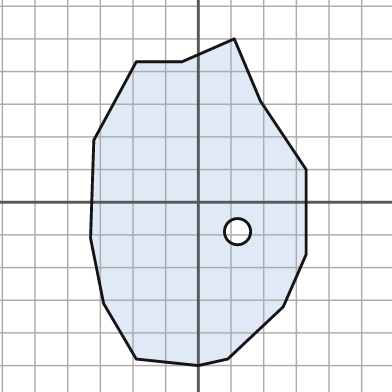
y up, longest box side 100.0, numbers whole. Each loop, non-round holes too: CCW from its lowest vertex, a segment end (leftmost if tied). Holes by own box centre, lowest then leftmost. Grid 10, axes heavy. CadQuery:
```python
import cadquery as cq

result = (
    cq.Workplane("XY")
    .moveTo(0.0, -50.0)
    .lineTo(9.0, -48.0)
    .lineTo(26.0, -32.0)
    .lineTo(33.0, -16.0)
    .lineTo(33.0, 10.0)
    .lineTo(19.0, 31.0)
    .lineTo(11.0, 50.0)
    .lineTo(-5.0, 43.0)
    .lineTo(-19.0, 43.0)
    .lineTo(-32.0, 19.0)
    .lineTo(-33.0, -11.0)
    .lineTo(-29.0, -31.0)
    .lineTo(-19.0, -48.0)
    .close()
    .moveTo(12.0, -9.0)
    .circle(4.0)
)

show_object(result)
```